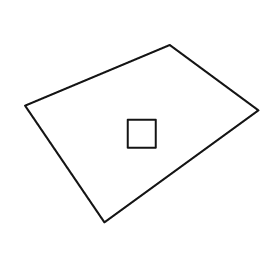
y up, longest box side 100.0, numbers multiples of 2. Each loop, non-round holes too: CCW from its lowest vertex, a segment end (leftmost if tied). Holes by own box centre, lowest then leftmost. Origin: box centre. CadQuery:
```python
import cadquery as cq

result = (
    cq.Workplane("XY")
    .moveTo(-16.0, -38.0)
    .lineTo(50.0, 10.0)
    .lineTo(12.0, 38.0)
    .lineTo(-50.0, 12.0)
    .close()
    .moveTo(-6.0, -6.0)
    .lineTo(6.0, -6.0)
    .lineTo(6.0, 6.0)
    .lineTo(-6.0, 6.0)
    .close()
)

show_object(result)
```